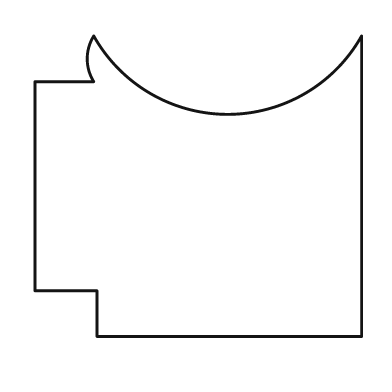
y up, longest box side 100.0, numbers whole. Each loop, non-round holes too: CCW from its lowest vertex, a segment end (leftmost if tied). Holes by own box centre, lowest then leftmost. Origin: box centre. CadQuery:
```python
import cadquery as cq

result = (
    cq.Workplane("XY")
    .moveTo(-31.0, -46.0)
    .lineTo(50.0, -46.0)
    .lineTo(50.0, 46.0)
    .threePointArc((9.0, 22.0), (-32.0, 46.0))
    .threePointArc((-34.0, 39.0), (-32.0, 32.0))
    .lineTo(-50.0, 32.0)
    .lineTo(-50.0, -32.0)
    .lineTo(-31.0, -32.0)
    .close()
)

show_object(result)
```